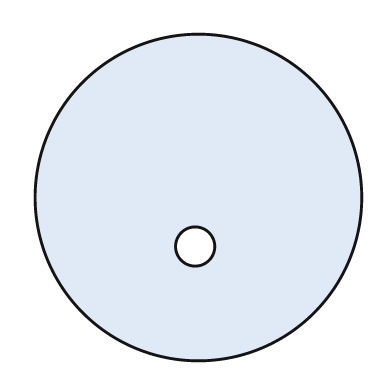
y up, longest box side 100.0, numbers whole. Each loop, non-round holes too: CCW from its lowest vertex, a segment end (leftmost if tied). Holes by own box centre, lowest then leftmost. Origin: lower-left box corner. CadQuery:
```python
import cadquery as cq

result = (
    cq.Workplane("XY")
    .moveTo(50.0, 50.0)
    .circle(50.0)
    .moveTo(49.0, 35.0)
    .circle(6.0)
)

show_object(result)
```